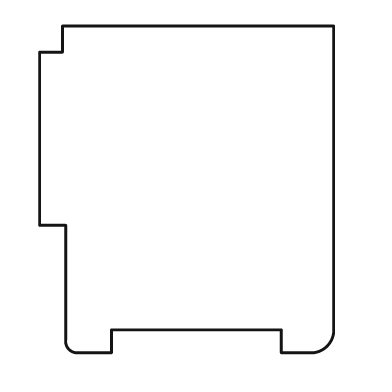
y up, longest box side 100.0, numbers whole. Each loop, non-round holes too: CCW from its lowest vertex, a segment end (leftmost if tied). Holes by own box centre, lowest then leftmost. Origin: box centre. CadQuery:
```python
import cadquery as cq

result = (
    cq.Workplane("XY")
    .moveTo(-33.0, -50.0)
    .lineTo(-23.0, -50.0)
    .lineTo(-23.0, -43.0)
    .lineTo(29.0, -43.0)
    .lineTo(29.0, -50.0)
    .lineTo(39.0, -50.0)
    .threePointArc((43.0, -48.0), (45.0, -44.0))
    .lineTo(45.0, 50.0)
    .lineTo(-38.0, 50.0)
    .lineTo(-38.0, 42.0)
    .lineTo(-45.0, 42.0)
    .lineTo(-45.0, -11.0)
    .lineTo(-37.0, -11.0)
    .lineTo(-37.0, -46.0)
    .threePointArc((-36.0, -49.0), (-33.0, -50.0))
    .close()
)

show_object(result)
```